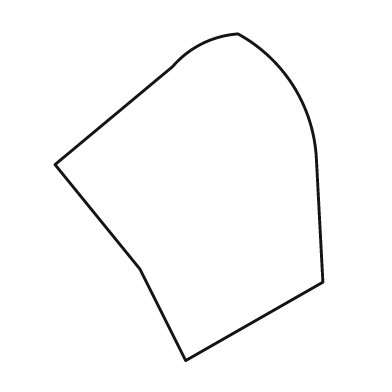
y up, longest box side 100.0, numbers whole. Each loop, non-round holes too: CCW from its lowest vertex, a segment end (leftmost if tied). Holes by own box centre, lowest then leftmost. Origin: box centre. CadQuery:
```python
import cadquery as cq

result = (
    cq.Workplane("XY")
    .moveTo(-1.0, -50.0)
    .lineTo(41.0, -26.0)
    .lineTo(39.0, 12.0)
    .threePointArc((32.0, 34.0), (15.0, 50.0))
    .threePointArc((4.0, 47.0), (-5.0, 40.0))
    .lineTo(-41.0, 10.0)
    .lineTo(-15.0, -22.0)
    .close()
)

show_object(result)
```